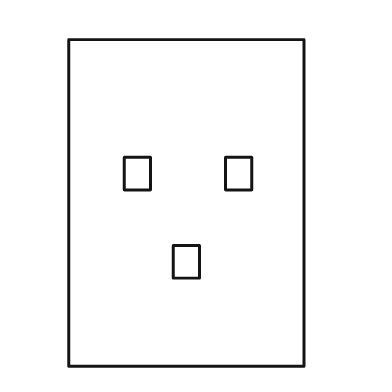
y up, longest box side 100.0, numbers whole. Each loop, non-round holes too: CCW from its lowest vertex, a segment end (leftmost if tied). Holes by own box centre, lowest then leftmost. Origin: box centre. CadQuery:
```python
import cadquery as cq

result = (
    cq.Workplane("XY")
    .moveTo(-36.0, -50.0)
    .lineTo(36.0, -50.0)
    .lineTo(36.0, 50.0)
    .lineTo(-36.0, 50.0)
    .close()
    .moveTo(-4.0, -23.0)
    .lineTo(4.0, -23.0)
    .lineTo(4.0, -13.0)
    .lineTo(-4.0, -13.0)
    .close()
    .moveTo(-19.0, 4.0)
    .lineTo(-11.0, 4.0)
    .lineTo(-11.0, 14.0)
    .lineTo(-19.0, 14.0)
    .close()
    .moveTo(12.0, 4.0)
    .lineTo(20.0, 4.0)
    .lineTo(20.0, 14.0)
    .lineTo(12.0, 14.0)
    .close()
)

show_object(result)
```